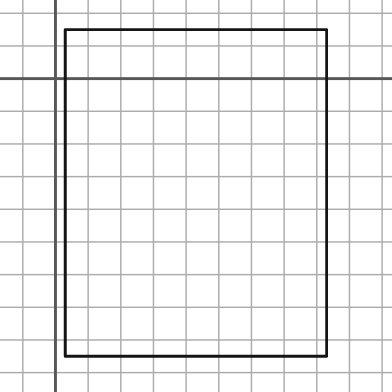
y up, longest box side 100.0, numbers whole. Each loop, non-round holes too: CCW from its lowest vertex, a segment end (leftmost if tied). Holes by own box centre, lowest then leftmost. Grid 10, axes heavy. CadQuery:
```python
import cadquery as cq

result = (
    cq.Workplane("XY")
    .moveTo(3.0, -85.0)
    .lineTo(83.0, -85.0)
    .lineTo(83.0, 15.0)
    .lineTo(3.0, 15.0)
    .close()
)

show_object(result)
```